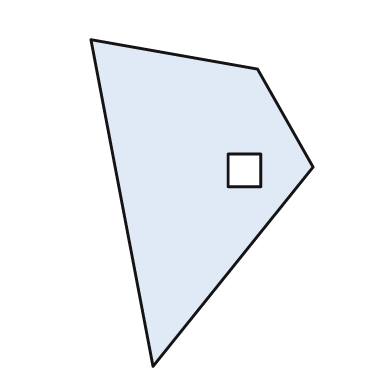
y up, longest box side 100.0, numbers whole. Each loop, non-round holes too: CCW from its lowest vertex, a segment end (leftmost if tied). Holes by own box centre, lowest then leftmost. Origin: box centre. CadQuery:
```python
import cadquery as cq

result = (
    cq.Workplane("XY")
    .moveTo(-15.0, -50.0)
    .lineTo(34.0, 11.0)
    .lineTo(17.0, 41.0)
    .lineTo(-34.0, 50.0)
    .close()
    .moveTo(8.0, 5.0)
    .lineTo(18.0, 5.0)
    .lineTo(18.0, 15.0)
    .lineTo(8.0, 15.0)
    .close()
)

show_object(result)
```